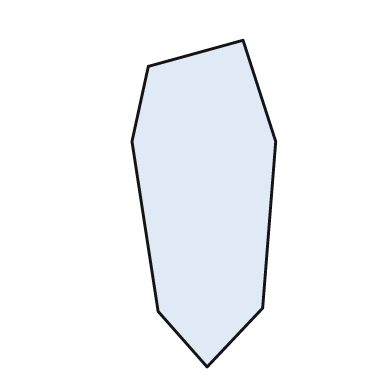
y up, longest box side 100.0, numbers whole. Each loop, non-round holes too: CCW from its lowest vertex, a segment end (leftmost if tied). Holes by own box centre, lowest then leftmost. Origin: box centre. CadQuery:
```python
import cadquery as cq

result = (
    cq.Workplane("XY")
    .moveTo(1.0, -50.0)
    .lineTo(18.0, -32.0)
    .lineTo(22.0, 19.0)
    .lineTo(12.0, 50.0)
    .lineTo(-17.0, 42.0)
    .lineTo(-22.0, 19.0)
    .lineTo(-14.0, -33.0)
    .close()
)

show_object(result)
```